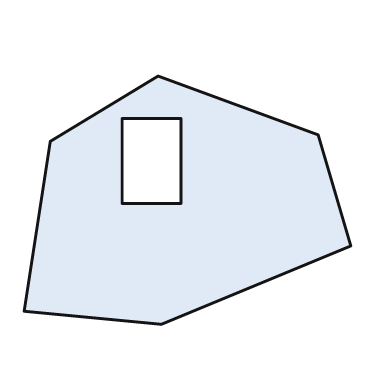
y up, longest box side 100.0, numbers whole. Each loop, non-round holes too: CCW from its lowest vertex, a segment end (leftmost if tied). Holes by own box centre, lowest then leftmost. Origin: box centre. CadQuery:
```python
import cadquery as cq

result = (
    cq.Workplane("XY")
    .moveTo(-8.0, -38.0)
    .lineTo(50.0, -14.0)
    .lineTo(40.0, 20.0)
    .lineTo(-9.0, 38.0)
    .lineTo(-42.0, 18.0)
    .lineTo(-50.0, -34.0)
    .close()
    .moveTo(-20.0, -1.0)
    .lineTo(-2.0, -1.0)
    .lineTo(-2.0, 25.0)
    .lineTo(-20.0, 25.0)
    .close()
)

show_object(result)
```